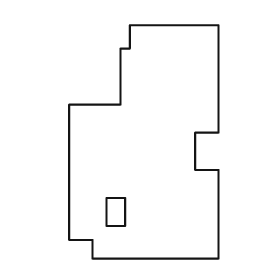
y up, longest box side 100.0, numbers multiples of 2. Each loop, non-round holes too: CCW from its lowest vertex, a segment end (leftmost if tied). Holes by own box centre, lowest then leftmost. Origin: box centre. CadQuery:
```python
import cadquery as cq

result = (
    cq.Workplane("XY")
    .moveTo(-22.0, -50.0)
    .lineTo(32.0, -50.0)
    .lineTo(32.0, -12.0)
    .lineTo(22.0, -12.0)
    .lineTo(22.0, 4.0)
    .lineTo(32.0, 4.0)
    .lineTo(32.0, 50.0)
    .lineTo(-6.0, 50.0)
    .lineTo(-6.0, 40.0)
    .lineTo(-10.0, 40.0)
    .lineTo(-10.0, 16.0)
    .lineTo(-32.0, 16.0)
    .lineTo(-32.0, -42.0)
    .lineTo(-22.0, -42.0)
    .close()
    .moveTo(-16.0, -36.0)
    .lineTo(-8.0, -36.0)
    .lineTo(-8.0, -24.0)
    .lineTo(-16.0, -24.0)
    .close()
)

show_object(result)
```